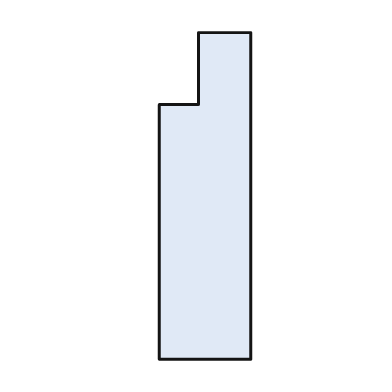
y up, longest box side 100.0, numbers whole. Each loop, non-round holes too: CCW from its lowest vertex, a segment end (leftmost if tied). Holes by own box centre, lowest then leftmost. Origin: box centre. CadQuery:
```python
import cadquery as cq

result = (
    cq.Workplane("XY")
    .moveTo(-14.0, -50.0)
    .lineTo(14.0, -50.0)
    .lineTo(14.0, 50.0)
    .lineTo(-2.0, 50.0)
    .lineTo(-2.0, 28.0)
    .lineTo(-14.0, 28.0)
    .close()
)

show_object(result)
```